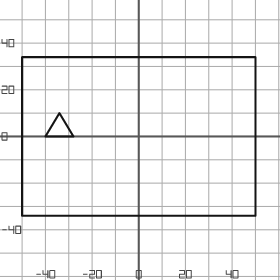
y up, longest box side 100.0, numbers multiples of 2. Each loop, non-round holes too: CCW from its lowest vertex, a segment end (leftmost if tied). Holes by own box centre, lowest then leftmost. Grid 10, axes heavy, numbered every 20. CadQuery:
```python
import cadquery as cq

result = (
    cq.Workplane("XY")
    .moveTo(-50.0, -34.0)
    .lineTo(50.0, -34.0)
    .lineTo(50.0, 34.0)
    .lineTo(-50.0, 34.0)
    .close()
    .moveTo(-40.0, 0.0)
    .lineTo(-28.0, 0.0)
    .lineTo(-34.0, 10.0)
    .close()
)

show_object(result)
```